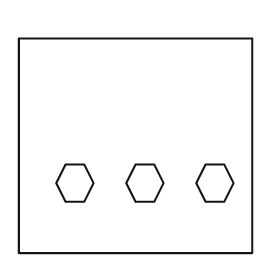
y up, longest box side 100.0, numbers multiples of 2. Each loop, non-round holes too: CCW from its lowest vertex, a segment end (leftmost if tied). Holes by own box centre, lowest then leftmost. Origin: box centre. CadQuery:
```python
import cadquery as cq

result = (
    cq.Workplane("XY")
    .moveTo(-50.0, -46.0)
    .lineTo(50.0, -46.0)
    .lineTo(50.0, 46.0)
    .lineTo(-50.0, 46.0)
    .close()
    .moveTo(-30.0, -24.0)
    .lineTo(-22.0, -24.0)
    .lineTo(-18.0, -16.0)
    .lineTo(-22.0, -8.0)
    .lineTo(-30.0, -8.0)
    .lineTo(-34.0, -16.0)
    .close()
    .moveTo(0.0, -24.0)
    .lineTo(8.0, -24.0)
    .lineTo(12.0, -16.0)
    .lineTo(8.0, -8.0)
    .lineTo(0.0, -8.0)
    .lineTo(-4.0, -16.0)
    .close()
    .moveTo(30.0, -24.0)
    .lineTo(38.0, -24.0)
    .lineTo(42.0, -16.0)
    .lineTo(38.0, -8.0)
    .lineTo(30.0, -8.0)
    .lineTo(26.0, -16.0)
    .close()
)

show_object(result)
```